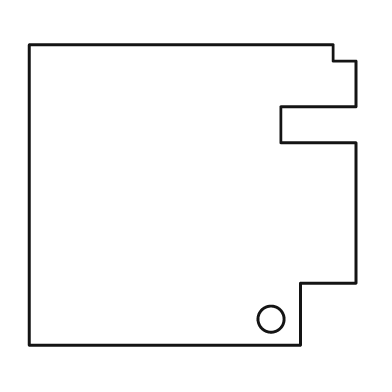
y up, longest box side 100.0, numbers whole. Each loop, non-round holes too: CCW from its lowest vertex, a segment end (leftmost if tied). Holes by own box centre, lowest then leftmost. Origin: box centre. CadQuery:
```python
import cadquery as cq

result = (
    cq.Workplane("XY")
    .moveTo(-50.0, -46.0)
    .lineTo(33.0, -46.0)
    .lineTo(33.0, -27.0)
    .lineTo(50.0, -27.0)
    .lineTo(50.0, 16.0)
    .lineTo(27.0, 16.0)
    .lineTo(27.0, 27.0)
    .lineTo(50.0, 27.0)
    .lineTo(50.0, 41.0)
    .lineTo(43.0, 41.0)
    .lineTo(43.0, 46.0)
    .lineTo(-50.0, 46.0)
    .close()
    .moveTo(24.0, -38.0)
    .circle(4.0)
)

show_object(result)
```